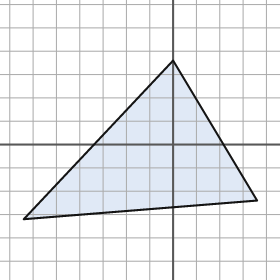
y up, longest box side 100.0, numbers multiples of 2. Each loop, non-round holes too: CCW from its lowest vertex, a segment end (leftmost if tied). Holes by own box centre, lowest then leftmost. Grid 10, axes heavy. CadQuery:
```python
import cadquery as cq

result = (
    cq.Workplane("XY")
    .moveTo(-64.0, -32.0)
    .lineTo(36.0, -24.0)
    .lineTo(0.0, 36.0)
    .close()
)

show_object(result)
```